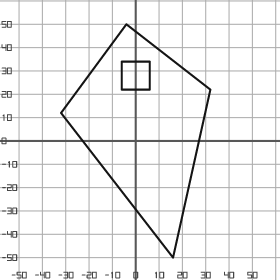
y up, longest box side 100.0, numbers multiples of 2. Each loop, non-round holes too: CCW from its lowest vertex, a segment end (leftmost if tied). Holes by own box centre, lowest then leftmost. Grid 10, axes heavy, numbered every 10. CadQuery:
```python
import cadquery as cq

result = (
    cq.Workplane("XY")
    .moveTo(16.0, -50.0)
    .lineTo(32.0, 22.0)
    .lineTo(-4.0, 50.0)
    .lineTo(-32.0, 12.0)
    .close()
    .moveTo(-6.0, 22.0)
    .lineTo(6.0, 22.0)
    .lineTo(6.0, 34.0)
    .lineTo(-6.0, 34.0)
    .close()
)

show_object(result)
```